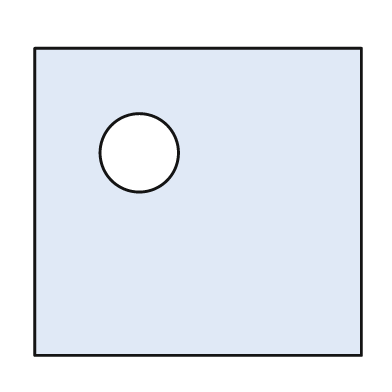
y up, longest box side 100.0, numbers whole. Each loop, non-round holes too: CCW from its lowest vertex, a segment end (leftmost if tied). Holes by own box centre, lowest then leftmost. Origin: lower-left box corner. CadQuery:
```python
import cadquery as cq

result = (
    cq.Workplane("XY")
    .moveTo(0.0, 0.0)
    .lineTo(100.0, 0.0)
    .lineTo(100.0, 94.0)
    .lineTo(0.0, 94.0)
    .close()
    .moveTo(32.0, 62.0)
    .circle(12.0)
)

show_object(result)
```